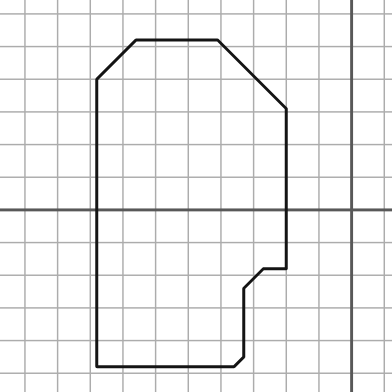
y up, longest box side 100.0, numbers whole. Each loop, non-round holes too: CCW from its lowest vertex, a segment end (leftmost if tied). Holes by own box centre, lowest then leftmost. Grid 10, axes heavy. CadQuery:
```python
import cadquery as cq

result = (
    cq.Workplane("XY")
    .moveTo(-78.0, -48.0)
    .lineTo(-36.0, -48.0)
    .lineTo(-33.0, -45.0)
    .lineTo(-33.0, -24.0)
    .lineTo(-27.0, -18.0)
    .lineTo(-20.0, -18.0)
    .lineTo(-20.0, 31.0)
    .lineTo(-41.0, 52.0)
    .lineTo(-66.0, 52.0)
    .lineTo(-78.0, 40.0)
    .close()
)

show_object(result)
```